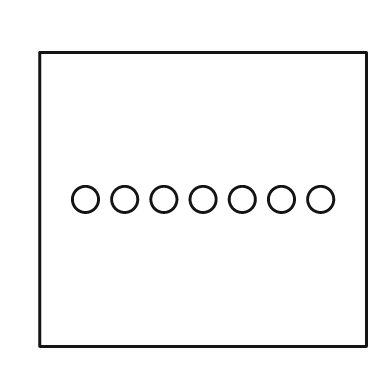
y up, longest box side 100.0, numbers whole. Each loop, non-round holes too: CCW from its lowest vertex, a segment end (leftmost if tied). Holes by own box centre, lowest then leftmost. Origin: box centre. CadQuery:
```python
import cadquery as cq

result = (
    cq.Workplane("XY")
    .moveTo(-50.0, -45.0)
    .lineTo(50.0, -45.0)
    .lineTo(50.0, 45.0)
    .lineTo(-50.0, 45.0)
    .close()
    .moveTo(-36.0, 0.0)
    .circle(4.0)
    .moveTo(-24.0, 0.0)
    .circle(4.0)
    .moveTo(-12.0, 0.0)
    .circle(4.0)
    .moveTo(0.0, 0.0)
    .circle(4.0)
    .moveTo(12.0, 0.0)
    .circle(4.0)
    .moveTo(24.0, 0.0)
    .circle(4.0)
    .moveTo(36.0, 0.0)
    .circle(4.0)
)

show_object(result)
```